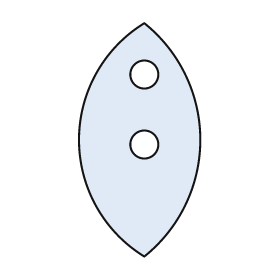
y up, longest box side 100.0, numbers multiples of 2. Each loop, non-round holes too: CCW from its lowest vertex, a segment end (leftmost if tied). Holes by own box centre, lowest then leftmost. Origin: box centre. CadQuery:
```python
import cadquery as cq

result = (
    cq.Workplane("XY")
    .moveTo(2.0, -50.0)
    .threePointArc((26.0, 0.0), (2.0, 50.0))
    .threePointArc((-26.0, 0.0), (2.0, -50.0))
    .close()
    .moveTo(2.0, -2.0)
    .circle(6.0)
    .moveTo(2.0, 28.0)
    .circle(6.0)
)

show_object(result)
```